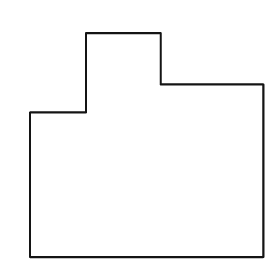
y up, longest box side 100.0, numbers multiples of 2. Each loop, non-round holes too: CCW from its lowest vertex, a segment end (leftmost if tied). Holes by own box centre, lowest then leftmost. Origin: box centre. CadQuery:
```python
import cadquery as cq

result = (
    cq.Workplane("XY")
    .moveTo(-50.0, -48.0)
    .lineTo(50.0, -48.0)
    .lineTo(50.0, 26.0)
    .lineTo(6.0, 26.0)
    .lineTo(6.0, 48.0)
    .lineTo(-26.0, 48.0)
    .lineTo(-26.0, 14.0)
    .lineTo(-50.0, 14.0)
    .close()
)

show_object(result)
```